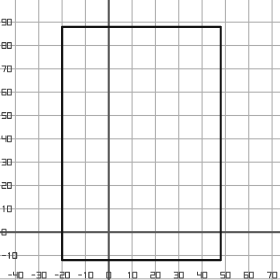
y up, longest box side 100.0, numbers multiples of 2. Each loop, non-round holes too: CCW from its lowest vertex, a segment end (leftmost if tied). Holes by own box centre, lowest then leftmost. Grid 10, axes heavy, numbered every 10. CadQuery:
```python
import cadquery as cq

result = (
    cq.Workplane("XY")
    .moveTo(-20.0, -12.0)
    .lineTo(48.0, -12.0)
    .lineTo(48.0, 88.0)
    .lineTo(-20.0, 88.0)
    .close()
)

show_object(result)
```